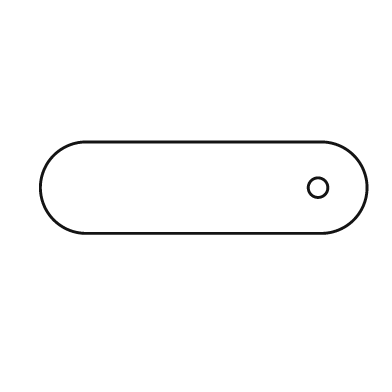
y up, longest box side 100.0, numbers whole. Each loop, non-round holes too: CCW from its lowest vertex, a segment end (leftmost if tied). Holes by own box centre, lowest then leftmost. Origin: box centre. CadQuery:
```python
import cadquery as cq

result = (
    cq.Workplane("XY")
    .moveTo(-36.0, -14.0)
    .lineTo(36.0, -14.0)
    .threePointArc((50.0, 0.0), (36.0, 14.0))
    .lineTo(-36.0, 14.0)
    .threePointArc((-50.0, 0.0), (-36.0, -14.0))
    .close()
    .moveTo(35.0, 0.0)
    .circle(3.0)
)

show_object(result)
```